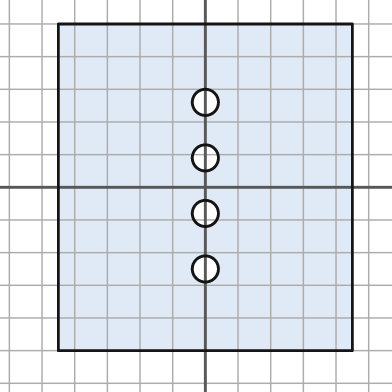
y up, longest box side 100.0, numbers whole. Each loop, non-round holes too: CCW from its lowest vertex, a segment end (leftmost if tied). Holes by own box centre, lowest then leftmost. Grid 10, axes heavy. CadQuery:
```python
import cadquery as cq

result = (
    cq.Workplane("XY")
    .moveTo(-45.0, -50.0)
    .lineTo(45.0, -50.0)
    .lineTo(45.0, 50.0)
    .lineTo(-45.0, 50.0)
    .close()
    .moveTo(0.0, -25.0)
    .circle(4.0)
    .moveTo(0.0, -8.0)
    .circle(4.0)
    .moveTo(0.0, 9.0)
    .circle(4.0)
    .moveTo(0.0, 26.0)
    .circle(4.0)
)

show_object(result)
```